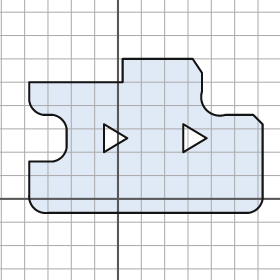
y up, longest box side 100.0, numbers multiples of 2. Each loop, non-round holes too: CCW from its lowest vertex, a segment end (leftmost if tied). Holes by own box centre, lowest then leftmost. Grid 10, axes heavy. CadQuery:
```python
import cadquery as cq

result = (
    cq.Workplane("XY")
    .moveTo(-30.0, -6.0)
    .lineTo(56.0, -6.0)
    .threePointArc((60.0, -4.0), (62.0, 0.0))
    .lineTo(62.0, 32.0)
    .lineTo(58.0, 36.0)
    .lineTo(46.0, 36.0)
    .threePointArc((38.0, 38.0), (36.0, 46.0))
    .lineTo(36.0, 54.0)
    .lineTo(32.0, 60.0)
    .lineTo(2.0, 60.0)
    .lineTo(2.0, 50.0)
    .lineTo(-38.0, 50.0)
    .lineTo(-38.0, 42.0)
    .threePointArc((-36.0, 38.0), (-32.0, 36.0))
    .lineTo(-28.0, 36.0)
    .threePointArc((-24.0, 34.0), (-22.0, 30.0))
    .lineTo(-22.0, 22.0)
    .threePointArc((-24.0, 18.0), (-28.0, 16.0))
    .lineTo(-38.0, 16.0)
    .lineTo(-38.0, 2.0)
    .threePointArc((-36.0, -4.0), (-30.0, -6.0))
    .close()
    .moveTo(-6.0, 20.0)
    .lineTo(4.0, 26.0)
    .lineTo(-6.0, 32.0)
    .close()
    .moveTo(28.0, 20.0)
    .lineTo(38.0, 26.0)
    .lineTo(28.0, 32.0)
    .close()
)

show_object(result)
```